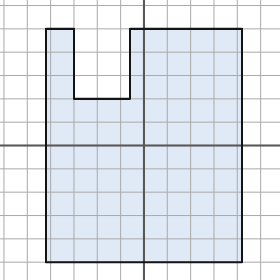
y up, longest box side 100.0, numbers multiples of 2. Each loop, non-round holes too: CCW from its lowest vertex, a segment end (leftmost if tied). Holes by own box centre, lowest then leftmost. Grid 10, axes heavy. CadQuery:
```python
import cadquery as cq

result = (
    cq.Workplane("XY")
    .moveTo(-42.0, -50.0)
    .lineTo(42.0, -50.0)
    .lineTo(42.0, 50.0)
    .lineTo(-6.0, 50.0)
    .lineTo(-6.0, 20.0)
    .lineTo(-30.0, 20.0)
    .lineTo(-30.0, 50.0)
    .lineTo(-42.0, 50.0)
    .close()
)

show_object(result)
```